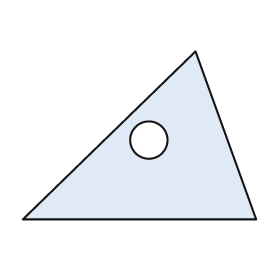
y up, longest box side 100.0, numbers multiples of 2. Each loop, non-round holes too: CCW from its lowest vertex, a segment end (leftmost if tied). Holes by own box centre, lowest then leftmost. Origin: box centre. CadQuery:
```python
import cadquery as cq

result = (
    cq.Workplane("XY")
    .moveTo(-50.0, -36.0)
    .lineTo(50.0, -36.0)
    .lineTo(24.0, 36.0)
    .close()
    .moveTo(4.0, -2.0)
    .circle(8.0)
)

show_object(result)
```